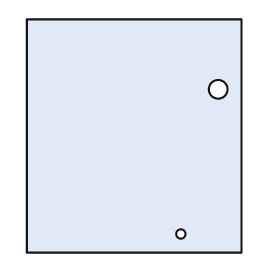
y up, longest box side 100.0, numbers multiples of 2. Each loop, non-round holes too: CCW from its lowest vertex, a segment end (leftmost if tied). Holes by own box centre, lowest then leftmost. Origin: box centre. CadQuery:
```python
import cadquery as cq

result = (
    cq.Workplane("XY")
    .moveTo(-46.0, -50.0)
    .lineTo(46.0, -50.0)
    .lineTo(46.0, 50.0)
    .lineTo(-46.0, 50.0)
    .close()
    .moveTo(20.0, -42.0)
    .circle(2.0)
    .moveTo(36.0, 20.0)
    .circle(4.0)
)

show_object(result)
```